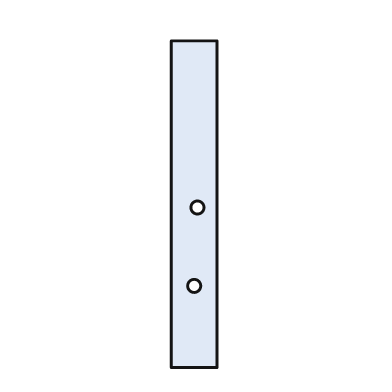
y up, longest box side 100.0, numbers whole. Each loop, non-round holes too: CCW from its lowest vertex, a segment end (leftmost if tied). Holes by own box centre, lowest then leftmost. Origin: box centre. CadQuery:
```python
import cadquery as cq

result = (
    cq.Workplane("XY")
    .moveTo(-7.0, -50.0)
    .lineTo(7.0, -50.0)
    .lineTo(7.0, 50.0)
    .lineTo(-7.0, 50.0)
    .close()
    .moveTo(0.0, -25.0)
    .circle(2.0)
    .moveTo(1.0, -1.0)
    .circle(2.0)
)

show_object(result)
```